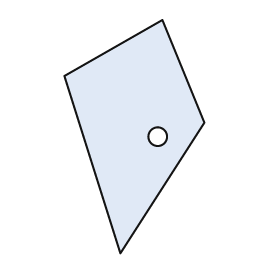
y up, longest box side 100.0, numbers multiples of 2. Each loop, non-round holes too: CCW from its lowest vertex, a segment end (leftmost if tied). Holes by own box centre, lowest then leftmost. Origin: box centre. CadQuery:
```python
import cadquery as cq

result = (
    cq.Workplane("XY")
    .moveTo(-6.0, -50.0)
    .lineTo(30.0, 6.0)
    .lineTo(12.0, 50.0)
    .lineTo(-30.0, 26.0)
    .close()
    .moveTo(10.0, 0.0)
    .circle(4.0)
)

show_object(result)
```